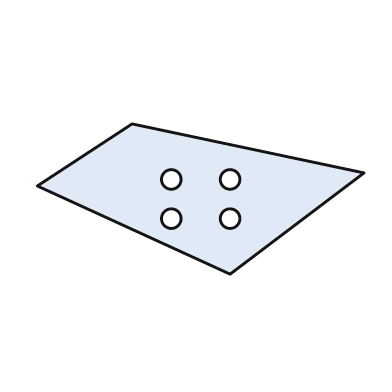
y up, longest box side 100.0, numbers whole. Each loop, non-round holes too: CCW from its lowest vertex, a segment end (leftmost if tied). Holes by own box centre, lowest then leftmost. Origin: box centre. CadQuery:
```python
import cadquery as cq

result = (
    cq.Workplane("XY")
    .moveTo(9.0, -23.0)
    .lineTo(50.0, 8.0)
    .lineTo(-21.0, 23.0)
    .lineTo(-50.0, 4.0)
    .close()
    .moveTo(-9.0, -6.0)
    .circle(3.0)
    .moveTo(9.0, -6.0)
    .circle(3.0)
    .moveTo(-9.0, 6.0)
    .circle(3.0)
    .moveTo(9.0, 6.0)
    .circle(3.0)
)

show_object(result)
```